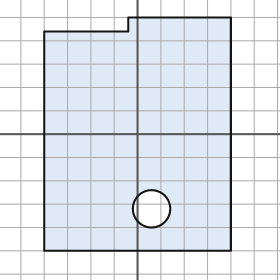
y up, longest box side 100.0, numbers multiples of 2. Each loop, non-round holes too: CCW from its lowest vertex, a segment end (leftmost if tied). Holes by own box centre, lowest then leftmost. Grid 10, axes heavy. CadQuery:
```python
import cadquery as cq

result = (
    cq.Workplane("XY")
    .moveTo(-40.0, -50.0)
    .lineTo(40.0, -50.0)
    .lineTo(40.0, 50.0)
    .lineTo(-4.0, 50.0)
    .lineTo(-4.0, 44.0)
    .lineTo(-40.0, 44.0)
    .close()
    .moveTo(6.0, -32.0)
    .circle(8.0)
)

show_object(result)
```